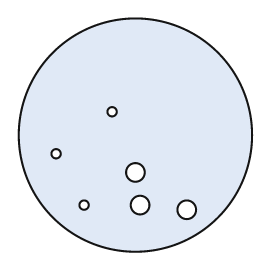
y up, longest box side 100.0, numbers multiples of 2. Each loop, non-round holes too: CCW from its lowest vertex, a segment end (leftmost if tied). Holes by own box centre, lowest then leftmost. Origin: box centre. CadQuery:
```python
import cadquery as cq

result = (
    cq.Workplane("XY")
    .moveTo(0.0, 0.0)
    .circle(50.0)
    .moveTo(22.0, -32.0)
    .circle(4.0)
    .moveTo(-22.0, -30.0)
    .circle(2.0)
    .moveTo(2.0, -30.0)
    .circle(4.0)
    .moveTo(0.0, -16.0)
    .circle(4.0)
    .moveTo(-34.0, -8.0)
    .circle(2.0)
    .moveTo(-10.0, 10.0)
    .circle(2.0)
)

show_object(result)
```